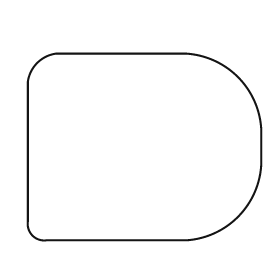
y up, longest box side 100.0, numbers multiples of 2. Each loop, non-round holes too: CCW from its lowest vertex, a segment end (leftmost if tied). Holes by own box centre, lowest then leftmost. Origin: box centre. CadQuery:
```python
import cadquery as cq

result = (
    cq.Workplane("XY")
    .moveTo(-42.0, -40.0)
    .lineTo(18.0, -40.0)
    .threePointArc((40.0, -30.0), (50.0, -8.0))
    .lineTo(50.0, 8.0)
    .threePointArc((40.0, 30.0), (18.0, 40.0))
    .lineTo(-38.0, 40.0)
    .threePointArc((-46.0, 36.0), (-50.0, 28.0))
    .lineTo(-50.0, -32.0)
    .threePointArc((-48.0, -38.0), (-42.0, -40.0))
    .close()
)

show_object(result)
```